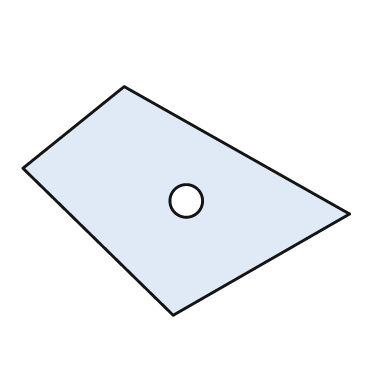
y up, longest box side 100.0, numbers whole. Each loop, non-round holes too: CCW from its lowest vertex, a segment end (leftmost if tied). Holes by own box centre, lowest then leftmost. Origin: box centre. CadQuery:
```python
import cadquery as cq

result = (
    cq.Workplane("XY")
    .moveTo(-4.0, -35.0)
    .lineTo(50.0, -4.0)
    .lineTo(-19.0, 35.0)
    .lineTo(-50.0, 10.0)
    .close()
    .moveTo(0.0, 0.0)
    .circle(5.0)
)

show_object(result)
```